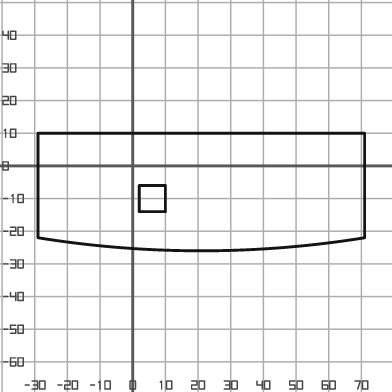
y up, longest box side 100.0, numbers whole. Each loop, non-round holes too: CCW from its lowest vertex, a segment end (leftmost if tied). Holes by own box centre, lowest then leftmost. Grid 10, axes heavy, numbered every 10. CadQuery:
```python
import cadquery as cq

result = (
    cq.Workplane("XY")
    .moveTo(-29.0, -22.0)
    .threePointArc((21.0, -26.0), (71.0, -22.0))
    .lineTo(71.0, 10.0)
    .lineTo(-29.0, 10.0)
    .close()
    .moveTo(2.0, -14.0)
    .lineTo(10.0, -14.0)
    .lineTo(10.0, -6.0)
    .lineTo(2.0, -6.0)
    .close()
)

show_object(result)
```